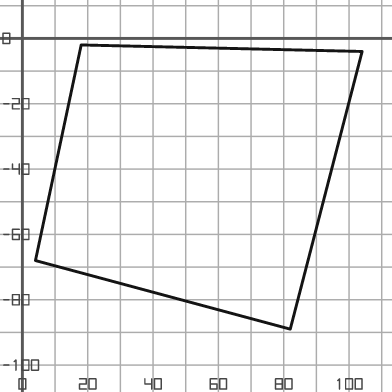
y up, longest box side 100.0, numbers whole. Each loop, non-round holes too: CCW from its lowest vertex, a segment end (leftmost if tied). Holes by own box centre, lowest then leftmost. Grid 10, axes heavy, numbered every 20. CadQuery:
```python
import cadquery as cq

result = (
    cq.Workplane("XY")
    .moveTo(82.0, -89.0)
    .lineTo(104.0, -4.0)
    .lineTo(18.0, -2.0)
    .lineTo(4.0, -68.0)
    .close()
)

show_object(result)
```